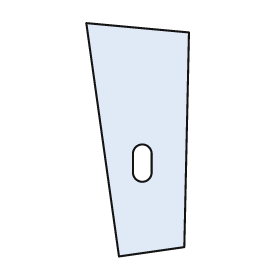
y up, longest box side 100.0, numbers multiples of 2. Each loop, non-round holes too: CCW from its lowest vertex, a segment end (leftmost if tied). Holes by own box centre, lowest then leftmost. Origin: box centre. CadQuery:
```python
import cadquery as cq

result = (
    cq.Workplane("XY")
    .moveTo(-8.0, -50.0)
    .lineTo(20.0, -46.0)
    .lineTo(22.0, 46.0)
    .lineTo(-22.0, 50.0)
    .close()
    .moveTo(-2.0, -14.0)
    .threePointArc((2.0, -18.0), (6.0, -14.0))
    .lineTo(6.0, -6.0)
    .threePointArc((2.0, -2.0), (-2.0, -6.0))
    .close()
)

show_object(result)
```